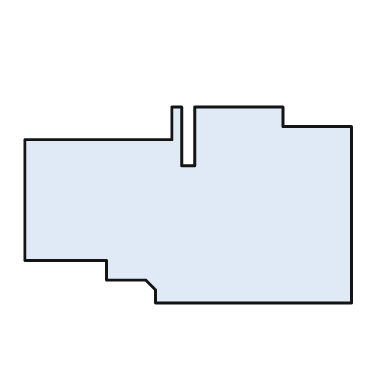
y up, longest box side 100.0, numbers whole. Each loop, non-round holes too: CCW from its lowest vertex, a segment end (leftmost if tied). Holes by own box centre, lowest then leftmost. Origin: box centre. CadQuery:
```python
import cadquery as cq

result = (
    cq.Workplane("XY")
    .moveTo(-10.0, -30.0)
    .lineTo(50.0, -30.0)
    .lineTo(50.0, 24.0)
    .lineTo(29.0, 24.0)
    .lineTo(29.0, 30.0)
    .lineTo(2.0, 30.0)
    .lineTo(2.0, 12.0)
    .lineTo(-2.0, 12.0)
    .lineTo(-2.0, 30.0)
    .lineTo(-5.0, 30.0)
    .lineTo(-5.0, 20.0)
    .lineTo(-50.0, 20.0)
    .lineTo(-50.0, -17.0)
    .lineTo(-25.0, -17.0)
    .lineTo(-25.0, -23.0)
    .lineTo(-13.0, -23.0)
    .lineTo(-10.0, -26.0)
    .close()
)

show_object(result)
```